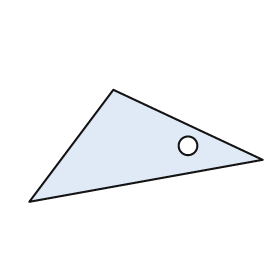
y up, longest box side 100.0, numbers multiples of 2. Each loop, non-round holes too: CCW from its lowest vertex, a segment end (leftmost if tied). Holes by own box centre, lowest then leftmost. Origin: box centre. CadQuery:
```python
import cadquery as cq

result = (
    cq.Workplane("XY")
    .moveTo(-50.0, -24.0)
    .lineTo(50.0, -6.0)
    .lineTo(-14.0, 24.0)
    .close()
    .moveTo(18.0, 0.0)
    .circle(4.0)
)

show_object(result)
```